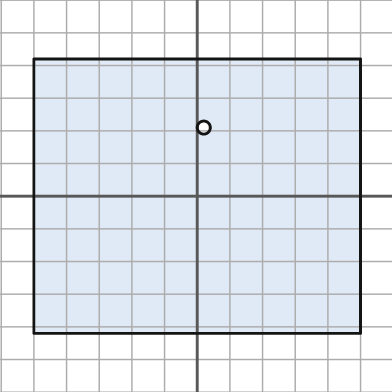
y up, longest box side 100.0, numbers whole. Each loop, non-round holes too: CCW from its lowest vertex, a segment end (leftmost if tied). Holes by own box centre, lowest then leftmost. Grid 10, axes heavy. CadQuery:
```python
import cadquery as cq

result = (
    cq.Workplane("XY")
    .moveTo(-50.0, -42.0)
    .lineTo(50.0, -42.0)
    .lineTo(50.0, 42.0)
    .lineTo(-50.0, 42.0)
    .close()
    .moveTo(2.0, 21.0)
    .circle(2.0)
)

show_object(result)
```